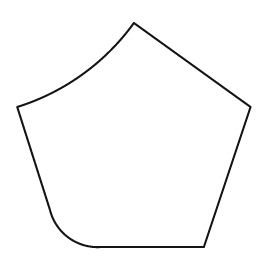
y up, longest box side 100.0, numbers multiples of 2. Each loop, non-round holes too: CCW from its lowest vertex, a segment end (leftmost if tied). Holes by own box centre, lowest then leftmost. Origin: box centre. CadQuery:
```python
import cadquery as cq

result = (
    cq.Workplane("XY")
    .moveTo(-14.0, -48.0)
    .lineTo(30.0, -48.0)
    .lineTo(50.0, 12.0)
    .lineTo(0.0, 48.0)
    .threePointArc((-22.0, 26.0), (-50.0, 12.0))
    .lineTo(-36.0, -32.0)
    .threePointArc((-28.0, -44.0), (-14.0, -48.0))
    .close()
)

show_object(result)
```